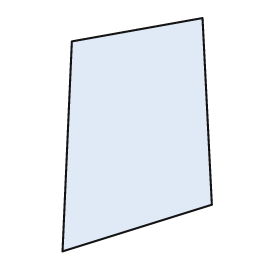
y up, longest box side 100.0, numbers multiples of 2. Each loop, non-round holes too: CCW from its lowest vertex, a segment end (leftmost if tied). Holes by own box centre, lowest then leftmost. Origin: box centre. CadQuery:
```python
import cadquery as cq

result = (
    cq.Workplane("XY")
    .moveTo(-32.0, -50.0)
    .lineTo(32.0, -30.0)
    .lineTo(28.0, 50.0)
    .lineTo(-28.0, 40.0)
    .close()
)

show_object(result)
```